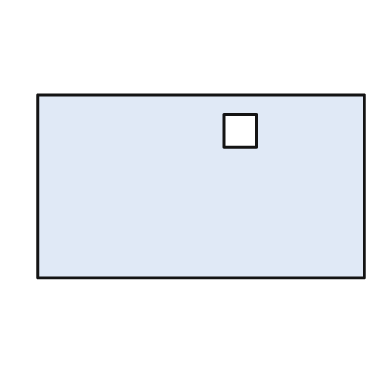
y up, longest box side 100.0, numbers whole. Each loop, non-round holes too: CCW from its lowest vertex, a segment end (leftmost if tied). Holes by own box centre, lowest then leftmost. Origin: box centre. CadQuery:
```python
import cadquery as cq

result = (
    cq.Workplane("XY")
    .moveTo(-50.0, -28.0)
    .lineTo(50.0, -28.0)
    .lineTo(50.0, 28.0)
    .lineTo(-50.0, 28.0)
    .close()
    .moveTo(7.0, 12.0)
    .lineTo(17.0, 12.0)
    .lineTo(17.0, 22.0)
    .lineTo(7.0, 22.0)
    .close()
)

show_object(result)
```